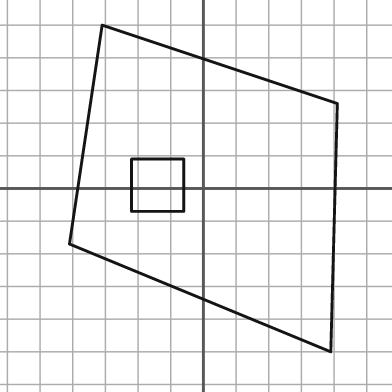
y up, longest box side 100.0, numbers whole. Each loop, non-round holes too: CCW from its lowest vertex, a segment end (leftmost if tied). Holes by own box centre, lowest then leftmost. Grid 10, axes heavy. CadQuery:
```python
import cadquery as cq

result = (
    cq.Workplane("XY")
    .moveTo(39.0, -50.0)
    .lineTo(41.0, 26.0)
    .lineTo(-31.0, 50.0)
    .lineTo(-41.0, -17.0)
    .close()
    .moveTo(-22.0, -7.0)
    .lineTo(-6.0, -7.0)
    .lineTo(-6.0, 9.0)
    .lineTo(-22.0, 9.0)
    .close()
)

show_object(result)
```